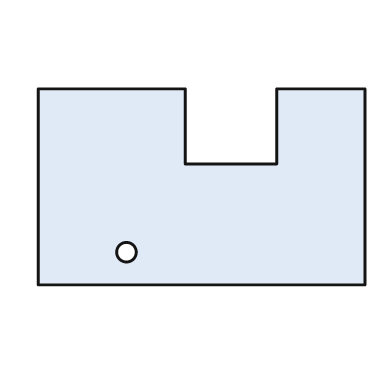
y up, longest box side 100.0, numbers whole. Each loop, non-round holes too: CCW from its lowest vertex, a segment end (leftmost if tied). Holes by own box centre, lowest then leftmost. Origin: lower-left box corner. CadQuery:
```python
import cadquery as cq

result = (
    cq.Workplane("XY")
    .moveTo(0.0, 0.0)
    .lineTo(100.0, 0.0)
    .lineTo(100.0, 60.0)
    .lineTo(73.0, 60.0)
    .lineTo(73.0, 37.0)
    .lineTo(45.0, 37.0)
    .lineTo(45.0, 60.0)
    .lineTo(0.0, 60.0)
    .close()
    .moveTo(27.0, 10.0)
    .circle(3.0)
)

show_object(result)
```